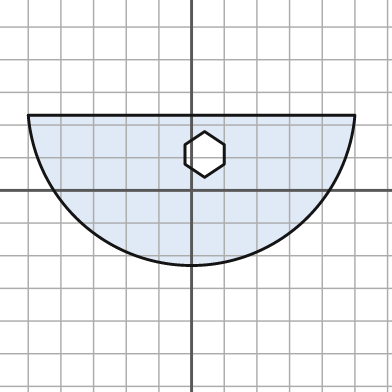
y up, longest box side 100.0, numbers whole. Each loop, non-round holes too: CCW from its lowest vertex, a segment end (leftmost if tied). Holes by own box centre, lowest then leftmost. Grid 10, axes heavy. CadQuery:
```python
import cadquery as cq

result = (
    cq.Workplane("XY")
    .moveTo(-50.0, 23.0)
    .threePointArc((0.0, -23.0), (50.0, 23.0))
    .close()
    .moveTo(4.0, 4.0)
    .lineTo(10.0, 8.0)
    .lineTo(10.0, 14.0)
    .lineTo(4.0, 18.0)
    .lineTo(-2.0, 14.0)
    .lineTo(-2.0, 8.0)
    .close()
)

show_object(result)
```